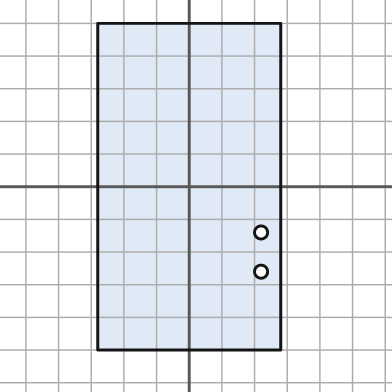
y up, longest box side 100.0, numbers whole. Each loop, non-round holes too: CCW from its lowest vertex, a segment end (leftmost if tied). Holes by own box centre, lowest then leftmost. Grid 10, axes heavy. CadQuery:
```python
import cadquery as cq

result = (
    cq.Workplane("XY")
    .moveTo(-28.0, -50.0)
    .lineTo(28.0, -50.0)
    .lineTo(28.0, 50.0)
    .lineTo(-28.0, 50.0)
    .close()
    .moveTo(22.0, -26.0)
    .circle(2.0)
    .moveTo(22.0, -14.0)
    .circle(2.0)
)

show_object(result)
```